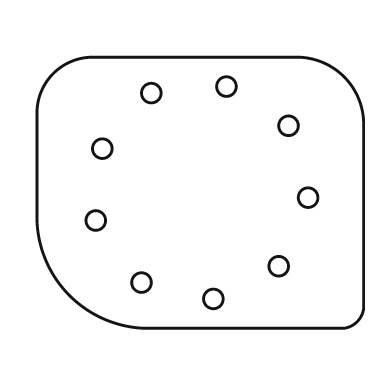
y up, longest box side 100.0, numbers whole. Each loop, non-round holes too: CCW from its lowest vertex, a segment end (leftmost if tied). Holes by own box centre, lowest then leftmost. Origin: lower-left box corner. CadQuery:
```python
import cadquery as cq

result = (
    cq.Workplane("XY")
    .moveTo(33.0, 0.0)
    .lineTo(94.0, 0.0)
    .threePointArc((98.0, 2.0), (100.0, 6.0))
    .lineTo(100.0, 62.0)
    .threePointArc((94.0, 77.0), (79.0, 83.0))
    .lineTo(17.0, 83.0)
    .threePointArc((5.0, 78.0), (0.0, 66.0))
    .lineTo(0.0, 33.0)
    .threePointArc((10.0, 10.0), (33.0, 0.0))
    .close()
    .moveTo(54.0, 9.0)
    .circle(3.0)
    .moveTo(32.0, 14.0)
    .circle(3.0)
    .moveTo(74.0, 19.0)
    .circle(3.0)
    .moveTo(18.0, 33.0)
    .circle(3.0)
    .moveTo(83.0, 40.0)
    .circle(3.0)
    .moveTo(20.0, 55.0)
    .circle(3.0)
    .moveTo(77.0, 62.0)
    .circle(3.0)
    .moveTo(35.0, 72.0)
    .circle(3.0)
    .moveTo(58.0, 74.0)
    .circle(3.0)
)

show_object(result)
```